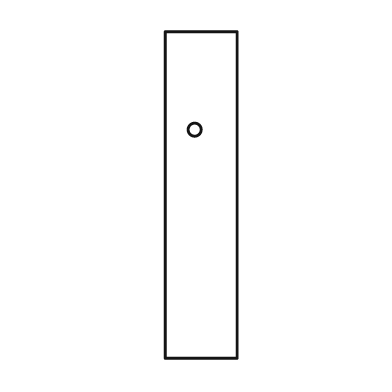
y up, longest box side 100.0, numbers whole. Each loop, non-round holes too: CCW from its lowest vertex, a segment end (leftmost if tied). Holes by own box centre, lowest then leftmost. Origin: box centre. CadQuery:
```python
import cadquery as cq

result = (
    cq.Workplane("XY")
    .moveTo(-11.0, -50.0)
    .lineTo(11.0, -50.0)
    .lineTo(11.0, 50.0)
    .lineTo(-11.0, 50.0)
    .close()
    .moveTo(-2.0, 20.0)
    .circle(2.0)
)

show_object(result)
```